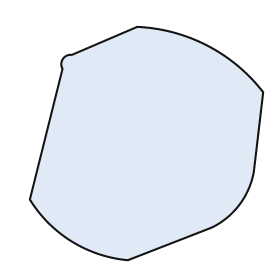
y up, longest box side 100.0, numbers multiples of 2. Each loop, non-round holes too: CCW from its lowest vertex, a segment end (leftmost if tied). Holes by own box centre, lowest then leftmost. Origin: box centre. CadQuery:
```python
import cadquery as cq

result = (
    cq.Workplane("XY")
    .moveTo(-8.0, -50.0)
    .lineTo(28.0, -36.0)
    .threePointArc((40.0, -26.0), (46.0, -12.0))
    .lineTo(50.0, 22.0)
    .threePointArc((26.0, 42.0), (-4.0, 50.0))
    .lineTo(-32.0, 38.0)
    .threePointArc((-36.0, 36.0), (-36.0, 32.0))
    .lineTo(-50.0, -24.0)
    .threePointArc((-32.0, -42.0), (-8.0, -50.0))
    .close()
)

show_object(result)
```